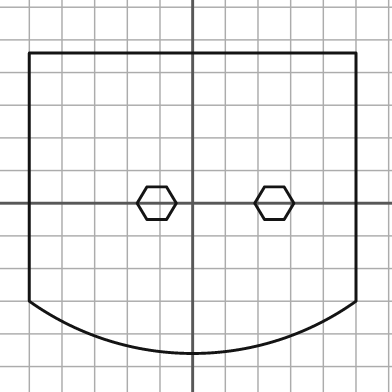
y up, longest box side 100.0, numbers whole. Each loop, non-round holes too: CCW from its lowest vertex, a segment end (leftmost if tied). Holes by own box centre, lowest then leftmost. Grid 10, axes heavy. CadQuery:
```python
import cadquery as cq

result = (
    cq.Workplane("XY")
    .moveTo(-50.0, -30.0)
    .threePointArc((0.0, -46.0), (50.0, -30.0))
    .lineTo(50.0, 46.0)
    .lineTo(-50.0, 46.0)
    .close()
    .moveTo(-14.0, -5.0)
    .lineTo(-8.0, -5.0)
    .lineTo(-5.0, 0.0)
    .lineTo(-8.0, 5.0)
    .lineTo(-14.0, 5.0)
    .lineTo(-17.0, 0.0)
    .close()
    .moveTo(22.0, -5.0)
    .lineTo(28.0, -5.0)
    .lineTo(31.0, 0.0)
    .lineTo(28.0, 5.0)
    .lineTo(22.0, 5.0)
    .lineTo(19.0, 0.0)
    .close()
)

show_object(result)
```